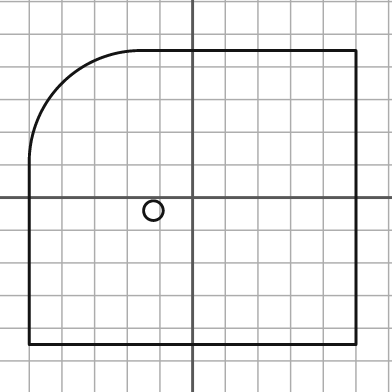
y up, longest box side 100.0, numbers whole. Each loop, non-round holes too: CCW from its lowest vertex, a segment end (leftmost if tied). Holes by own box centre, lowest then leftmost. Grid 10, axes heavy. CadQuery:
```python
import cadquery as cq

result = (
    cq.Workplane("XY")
    .moveTo(-50.0, -45.0)
    .lineTo(50.0, -45.0)
    .lineTo(50.0, 45.0)
    .lineTo(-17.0, 45.0)
    .threePointArc((-40.0, 35.0), (-50.0, 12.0))
    .close()
    .moveTo(-12.0, -4.0)
    .circle(3.0)
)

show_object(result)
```